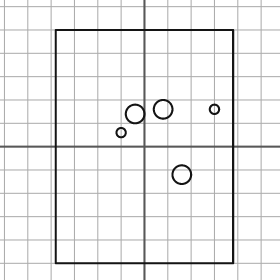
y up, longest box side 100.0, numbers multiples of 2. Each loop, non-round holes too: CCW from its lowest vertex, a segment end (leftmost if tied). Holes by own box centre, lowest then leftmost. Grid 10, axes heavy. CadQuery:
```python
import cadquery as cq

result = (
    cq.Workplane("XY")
    .moveTo(-38.0, -50.0)
    .lineTo(38.0, -50.0)
    .lineTo(38.0, 50.0)
    .lineTo(-38.0, 50.0)
    .close()
    .moveTo(16.0, -12.0)
    .circle(4.0)
    .moveTo(-10.0, 6.0)
    .circle(2.0)
    .moveTo(-4.0, 14.0)
    .circle(4.0)
    .moveTo(8.0, 16.0)
    .circle(4.0)
    .moveTo(30.0, 16.0)
    .circle(2.0)
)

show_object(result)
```